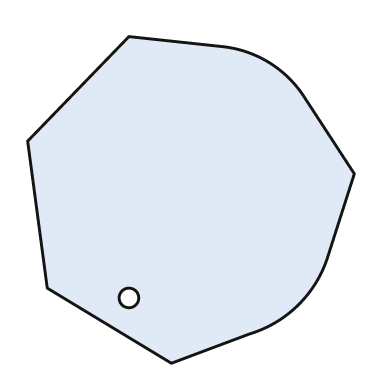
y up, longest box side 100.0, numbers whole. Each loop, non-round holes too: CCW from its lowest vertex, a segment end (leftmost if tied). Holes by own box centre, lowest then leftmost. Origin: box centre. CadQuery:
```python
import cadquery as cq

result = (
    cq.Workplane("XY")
    .moveTo(-6.0, -50.0)
    .lineTo(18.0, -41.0)
    .threePointArc((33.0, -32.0), (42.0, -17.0))
    .lineTo(50.0, 8.0)
    .lineTo(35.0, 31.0)
    .threePointArc((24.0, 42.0), (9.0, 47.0))
    .lineTo(-19.0, 50.0)
    .lineTo(-50.0, 18.0)
    .lineTo(-44.0, -27.0)
    .close()
    .moveTo(-19.0, -30.0)
    .circle(3.0)
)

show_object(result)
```